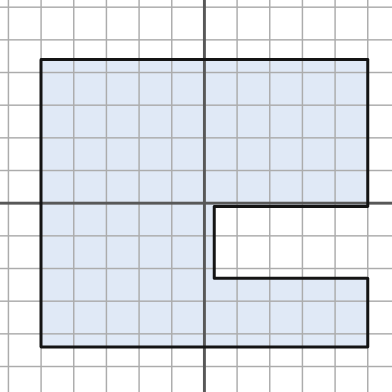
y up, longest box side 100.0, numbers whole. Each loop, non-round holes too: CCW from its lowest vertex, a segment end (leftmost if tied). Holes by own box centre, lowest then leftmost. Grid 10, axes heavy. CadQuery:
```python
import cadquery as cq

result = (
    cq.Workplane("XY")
    .moveTo(-50.0, -44.0)
    .lineTo(50.0, -44.0)
    .lineTo(50.0, -23.0)
    .lineTo(3.0, -23.0)
    .lineTo(3.0, -1.0)
    .lineTo(50.0, -1.0)
    .lineTo(50.0, 44.0)
    .lineTo(-50.0, 44.0)
    .close()
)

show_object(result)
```